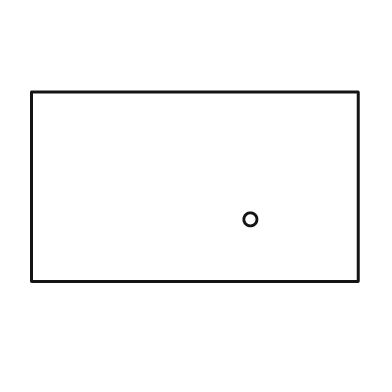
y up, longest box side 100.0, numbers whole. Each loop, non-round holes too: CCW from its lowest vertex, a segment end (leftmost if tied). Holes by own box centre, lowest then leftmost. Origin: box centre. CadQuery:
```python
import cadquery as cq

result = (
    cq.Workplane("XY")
    .moveTo(-50.0, -29.0)
    .lineTo(50.0, -29.0)
    .lineTo(50.0, 29.0)
    .lineTo(-50.0, 29.0)
    .close()
    .moveTo(17.0, -10.0)
    .circle(2.0)
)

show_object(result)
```